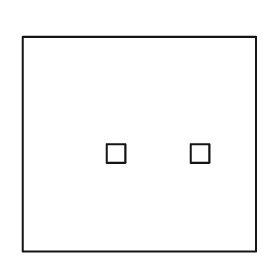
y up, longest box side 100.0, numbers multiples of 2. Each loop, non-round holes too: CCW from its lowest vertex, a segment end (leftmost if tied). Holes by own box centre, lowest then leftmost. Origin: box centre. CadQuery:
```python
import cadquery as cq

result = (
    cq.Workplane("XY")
    .moveTo(-50.0, -46.0)
    .lineTo(50.0, -46.0)
    .lineTo(50.0, 46.0)
    .lineTo(-50.0, 46.0)
    .close()
    .moveTo(-14.0, -8.0)
    .lineTo(-6.0, -8.0)
    .lineTo(-6.0, 0.0)
    .lineTo(-14.0, 0.0)
    .close()
    .moveTo(22.0, -8.0)
    .lineTo(30.0, -8.0)
    .lineTo(30.0, 0.0)
    .lineTo(22.0, 0.0)
    .close()
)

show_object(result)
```